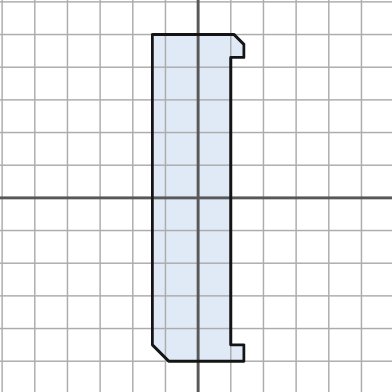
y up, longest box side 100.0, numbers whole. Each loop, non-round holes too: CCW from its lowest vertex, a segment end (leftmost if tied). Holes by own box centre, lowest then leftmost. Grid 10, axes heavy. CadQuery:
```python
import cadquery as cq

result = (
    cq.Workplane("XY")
    .moveTo(-9.0, -50.0)
    .lineTo(14.0, -50.0)
    .lineTo(14.0, -45.0)
    .lineTo(10.0, -45.0)
    .lineTo(10.0, 43.0)
    .lineTo(14.0, 43.0)
    .lineTo(14.0, 47.0)
    .lineTo(11.0, 50.0)
    .lineTo(-14.0, 50.0)
    .lineTo(-14.0, -45.0)
    .close()
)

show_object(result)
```